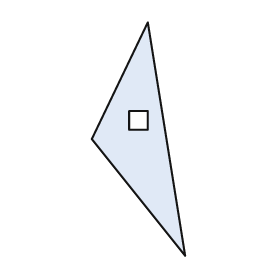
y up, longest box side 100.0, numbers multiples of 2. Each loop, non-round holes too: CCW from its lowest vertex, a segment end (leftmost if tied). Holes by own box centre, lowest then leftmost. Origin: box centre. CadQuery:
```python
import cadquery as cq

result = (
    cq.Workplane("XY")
    .moveTo(20.0, -50.0)
    .lineTo(4.0, 50.0)
    .lineTo(-20.0, 0.0)
    .close()
    .moveTo(-4.0, 4.0)
    .lineTo(4.0, 4.0)
    .lineTo(4.0, 12.0)
    .lineTo(-4.0, 12.0)
    .close()
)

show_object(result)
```